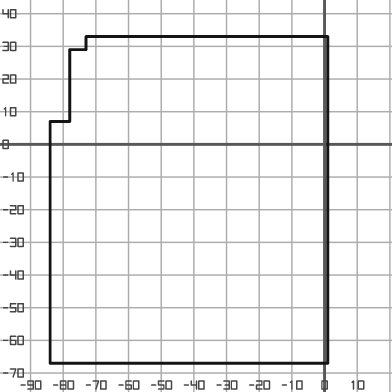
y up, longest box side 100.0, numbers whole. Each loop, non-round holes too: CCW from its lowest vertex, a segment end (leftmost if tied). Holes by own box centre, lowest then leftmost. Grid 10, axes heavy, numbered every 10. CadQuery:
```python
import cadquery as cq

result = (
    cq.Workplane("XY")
    .moveTo(-84.0, -67.0)
    .lineTo(1.0, -67.0)
    .lineTo(1.0, 33.0)
    .lineTo(-73.0, 33.0)
    .lineTo(-73.0, 29.0)
    .lineTo(-78.0, 29.0)
    .lineTo(-78.0, 7.0)
    .lineTo(-84.0, 7.0)
    .close()
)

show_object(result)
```